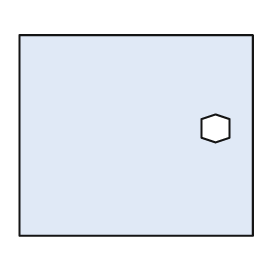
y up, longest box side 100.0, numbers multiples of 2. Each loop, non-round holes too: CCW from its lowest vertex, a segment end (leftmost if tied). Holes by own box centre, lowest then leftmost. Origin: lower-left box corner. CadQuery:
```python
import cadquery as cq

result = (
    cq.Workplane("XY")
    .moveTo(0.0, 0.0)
    .lineTo(100.0, 0.0)
    .lineTo(100.0, 86.0)
    .lineTo(0.0, 86.0)
    .close()
    .moveTo(84.0, 40.0)
    .lineTo(90.0, 42.0)
    .lineTo(90.0, 50.0)
    .lineTo(84.0, 52.0)
    .lineTo(78.0, 50.0)
    .lineTo(78.0, 42.0)
    .close()
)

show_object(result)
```